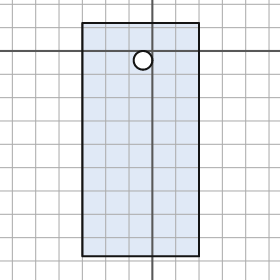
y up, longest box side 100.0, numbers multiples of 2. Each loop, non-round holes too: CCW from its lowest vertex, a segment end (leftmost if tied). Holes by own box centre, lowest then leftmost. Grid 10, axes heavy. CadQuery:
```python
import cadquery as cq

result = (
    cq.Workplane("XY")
    .moveTo(-30.0, -88.0)
    .lineTo(20.0, -88.0)
    .lineTo(20.0, 12.0)
    .lineTo(-30.0, 12.0)
    .close()
    .moveTo(-4.0, -4.0)
    .circle(4.0)
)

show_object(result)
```